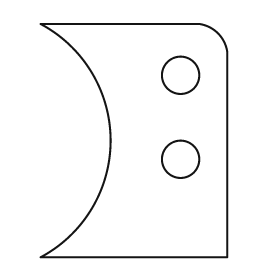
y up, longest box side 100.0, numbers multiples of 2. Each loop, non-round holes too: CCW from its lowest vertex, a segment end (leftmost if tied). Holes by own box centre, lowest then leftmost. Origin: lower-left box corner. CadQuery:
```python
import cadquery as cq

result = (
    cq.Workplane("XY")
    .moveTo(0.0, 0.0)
    .lineTo(80.0, 0.0)
    .lineTo(80.0, 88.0)
    .threePointArc((76.0, 96.0), (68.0, 100.0))
    .lineTo(0.0, 100.0)
    .threePointArc((30.0, 50.0), (0.0, 0.0))
    .close()
    .moveTo(60.0, 42.0)
    .circle(8.0)
    .moveTo(60.0, 78.0)
    .circle(8.0)
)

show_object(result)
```